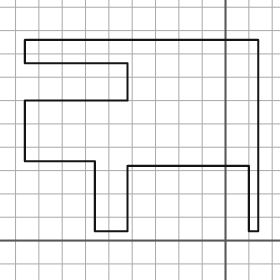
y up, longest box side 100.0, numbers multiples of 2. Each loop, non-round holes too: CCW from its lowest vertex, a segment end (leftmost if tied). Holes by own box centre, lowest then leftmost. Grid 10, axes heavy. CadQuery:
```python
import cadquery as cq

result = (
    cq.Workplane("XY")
    .moveTo(-56.0, 4.0)
    .lineTo(-42.0, 4.0)
    .lineTo(-42.0, 32.0)
    .lineTo(10.0, 32.0)
    .lineTo(10.0, 4.0)
    .lineTo(14.0, 4.0)
    .lineTo(14.0, 86.0)
    .lineTo(-86.0, 86.0)
    .lineTo(-86.0, 76.0)
    .lineTo(-42.0, 76.0)
    .lineTo(-42.0, 60.0)
    .lineTo(-86.0, 60.0)
    .lineTo(-86.0, 34.0)
    .lineTo(-56.0, 34.0)
    .close()
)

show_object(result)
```